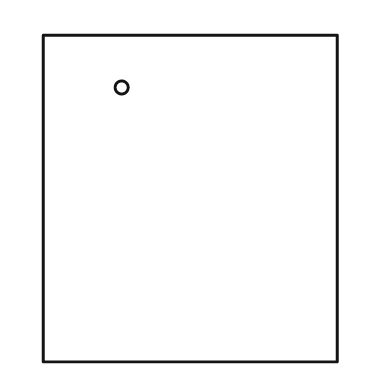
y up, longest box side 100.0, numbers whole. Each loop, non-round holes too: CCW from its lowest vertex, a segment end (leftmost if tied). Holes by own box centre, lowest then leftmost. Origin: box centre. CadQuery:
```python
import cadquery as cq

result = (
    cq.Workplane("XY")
    .moveTo(-45.0, -50.0)
    .lineTo(45.0, -50.0)
    .lineTo(45.0, 50.0)
    .lineTo(-45.0, 50.0)
    .close()
    .moveTo(-21.0, 34.0)
    .circle(2.0)
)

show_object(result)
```